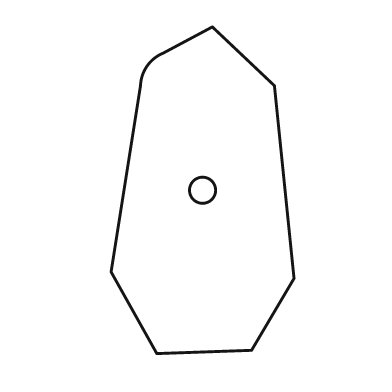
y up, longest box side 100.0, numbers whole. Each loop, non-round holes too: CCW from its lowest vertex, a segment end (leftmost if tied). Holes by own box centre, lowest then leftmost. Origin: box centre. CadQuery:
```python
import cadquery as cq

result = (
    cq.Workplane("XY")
    .moveTo(-14.0, -50.0)
    .lineTo(15.0, -49.0)
    .lineTo(28.0, -27.0)
    .lineTo(22.0, 32.0)
    .lineTo(3.0, 50.0)
    .lineTo(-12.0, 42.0)
    .threePointArc((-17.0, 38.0), (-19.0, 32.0))
    .lineTo(-28.0, -25.0)
    .close()
    .moveTo(0.0, 0.0)
    .circle(4.0)
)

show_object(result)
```